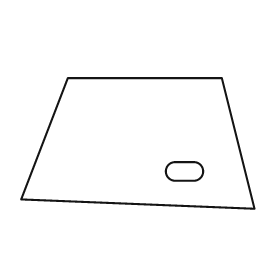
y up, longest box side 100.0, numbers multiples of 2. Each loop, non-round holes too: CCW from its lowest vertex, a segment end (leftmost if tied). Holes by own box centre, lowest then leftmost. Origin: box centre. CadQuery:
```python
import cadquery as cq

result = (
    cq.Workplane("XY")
    .moveTo(50.0, -28.0)
    .lineTo(36.0, 28.0)
    .lineTo(-30.0, 28.0)
    .lineTo(-50.0, -24.0)
    .close()
    .moveTo(16.0, -16.0)
    .lineTo(24.0, -16.0)
    .threePointArc((28.0, -12.0), (24.0, -8.0))
    .lineTo(16.0, -8.0)
    .threePointArc((12.0, -12.0), (16.0, -16.0))
    .close()
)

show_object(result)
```